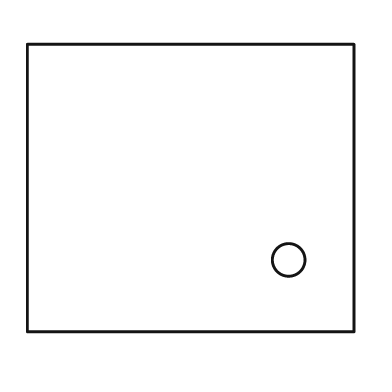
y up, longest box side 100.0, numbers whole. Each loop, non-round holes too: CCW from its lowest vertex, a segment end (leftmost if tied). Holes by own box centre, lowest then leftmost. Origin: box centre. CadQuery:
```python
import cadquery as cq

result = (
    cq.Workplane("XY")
    .moveTo(-50.0, -44.0)
    .lineTo(50.0, -44.0)
    .lineTo(50.0, 44.0)
    .lineTo(-50.0, 44.0)
    .close()
    .moveTo(30.0, -22.0)
    .circle(5.0)
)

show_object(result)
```